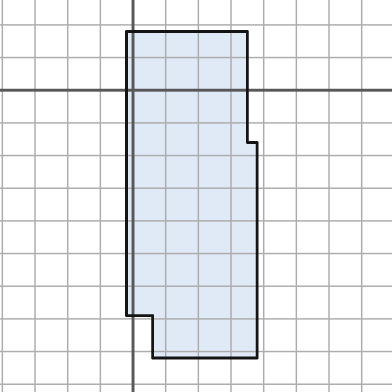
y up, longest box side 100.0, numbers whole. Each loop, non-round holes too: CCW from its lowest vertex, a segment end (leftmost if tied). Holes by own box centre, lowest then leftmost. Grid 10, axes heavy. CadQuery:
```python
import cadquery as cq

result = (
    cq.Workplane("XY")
    .moveTo(6.0, -82.0)
    .lineTo(38.0, -82.0)
    .lineTo(38.0, -16.0)
    .lineTo(35.0, -16.0)
    .lineTo(35.0, 18.0)
    .lineTo(-2.0, 18.0)
    .lineTo(-2.0, -69.0)
    .lineTo(6.0, -69.0)
    .close()
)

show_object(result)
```